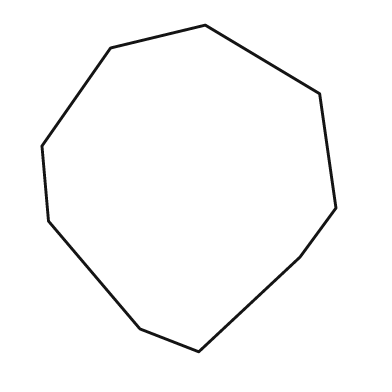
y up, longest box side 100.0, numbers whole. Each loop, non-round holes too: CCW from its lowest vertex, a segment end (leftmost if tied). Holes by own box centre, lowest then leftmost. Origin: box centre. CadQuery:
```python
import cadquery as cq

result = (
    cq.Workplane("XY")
    .moveTo(3.0, -50.0)
    .lineTo(34.0, -21.0)
    .lineTo(45.0, -6.0)
    .lineTo(40.0, 29.0)
    .lineTo(5.0, 50.0)
    .lineTo(-24.0, 43.0)
    .lineTo(-45.0, 13.0)
    .lineTo(-43.0, -10.0)
    .lineTo(-15.0, -43.0)
    .close()
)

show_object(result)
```